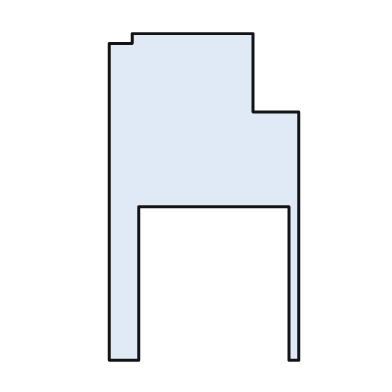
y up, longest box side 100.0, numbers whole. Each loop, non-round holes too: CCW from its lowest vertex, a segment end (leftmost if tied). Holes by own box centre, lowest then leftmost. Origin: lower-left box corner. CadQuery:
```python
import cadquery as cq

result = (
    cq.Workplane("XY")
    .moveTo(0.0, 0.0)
    .lineTo(9.0, 0.0)
    .lineTo(9.0, 47.0)
    .lineTo(55.0, 47.0)
    .lineTo(55.0, 0.0)
    .lineTo(58.0, 0.0)
    .lineTo(58.0, 76.0)
    .lineTo(44.0, 76.0)
    .lineTo(44.0, 100.0)
    .lineTo(7.0, 100.0)
    .lineTo(7.0, 97.0)
    .lineTo(0.0, 97.0)
    .close()
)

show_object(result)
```